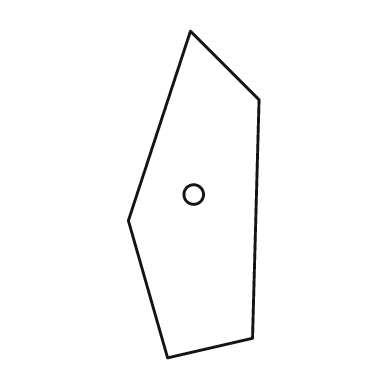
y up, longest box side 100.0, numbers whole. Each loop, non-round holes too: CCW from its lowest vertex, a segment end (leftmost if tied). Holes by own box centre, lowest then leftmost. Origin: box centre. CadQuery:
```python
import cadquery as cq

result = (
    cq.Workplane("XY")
    .moveTo(-8.0, -50.0)
    .lineTo(18.0, -44.0)
    .lineTo(20.0, 29.0)
    .lineTo(-1.0, 50.0)
    .lineTo(-20.0, -8.0)
    .close()
    .moveTo(0.0, 0.0)
    .circle(3.0)
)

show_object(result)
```